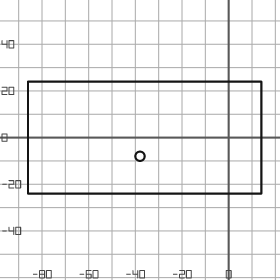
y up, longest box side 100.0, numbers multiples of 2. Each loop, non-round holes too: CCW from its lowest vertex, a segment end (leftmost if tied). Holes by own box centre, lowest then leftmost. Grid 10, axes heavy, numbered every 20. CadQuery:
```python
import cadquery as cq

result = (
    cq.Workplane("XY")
    .moveTo(-86.0, -24.0)
    .lineTo(14.0, -24.0)
    .lineTo(14.0, 24.0)
    .lineTo(-86.0, 24.0)
    .close()
    .moveTo(-38.0, -8.0)
    .circle(2.0)
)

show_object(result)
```